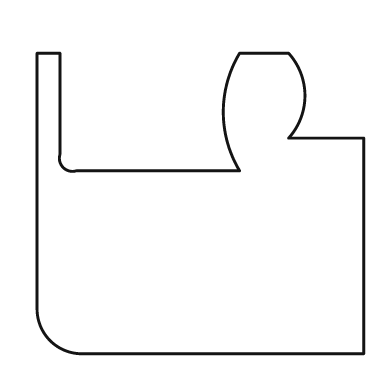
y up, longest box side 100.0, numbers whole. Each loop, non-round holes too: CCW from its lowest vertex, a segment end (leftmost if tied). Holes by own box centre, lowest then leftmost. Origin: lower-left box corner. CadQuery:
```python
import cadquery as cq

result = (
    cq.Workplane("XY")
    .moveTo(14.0, 0.0)
    .lineTo(100.0, 0.0)
    .lineTo(100.0, 66.0)
    .lineTo(77.0, 66.0)
    .threePointArc((82.0, 79.0), (77.0, 92.0))
    .lineTo(62.0, 92.0)
    .threePointArc((57.0, 74.0), (62.0, 56.0))
    .lineTo(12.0, 56.0)
    .threePointArc((8.0, 57.0), (7.0, 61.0))
    .lineTo(7.0, 92.0)
    .lineTo(0.0, 92.0)
    .lineTo(0.0, 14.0)
    .threePointArc((4.0, 4.0), (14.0, 0.0))
    .close()
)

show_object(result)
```